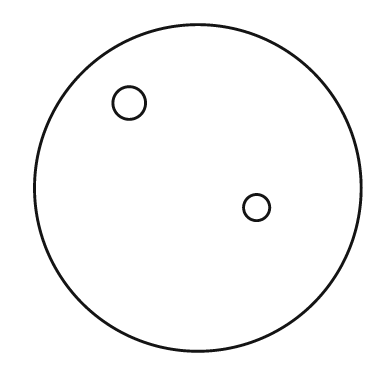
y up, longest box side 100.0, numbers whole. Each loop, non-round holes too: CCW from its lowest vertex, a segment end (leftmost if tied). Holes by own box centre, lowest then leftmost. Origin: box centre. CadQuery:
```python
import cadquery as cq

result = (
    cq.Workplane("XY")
    .moveTo(0.0, 0.0)
    .circle(50.0)
    .moveTo(18.0, -6.0)
    .circle(4.0)
    .moveTo(-21.0, 26.0)
    .circle(5.0)
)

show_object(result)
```